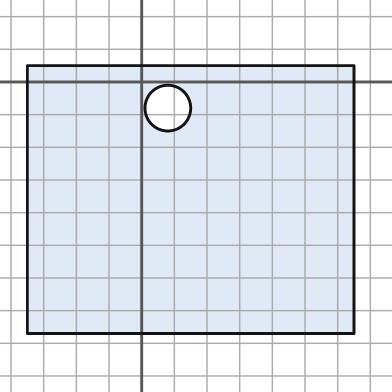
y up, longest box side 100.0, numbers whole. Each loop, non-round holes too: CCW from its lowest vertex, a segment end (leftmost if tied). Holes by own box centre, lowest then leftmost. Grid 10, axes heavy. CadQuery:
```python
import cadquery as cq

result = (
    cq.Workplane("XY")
    .moveTo(-35.0, -77.0)
    .lineTo(65.0, -77.0)
    .lineTo(65.0, 5.0)
    .lineTo(-35.0, 5.0)
    .close()
    .moveTo(8.0, -8.0)
    .circle(7.0)
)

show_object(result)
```